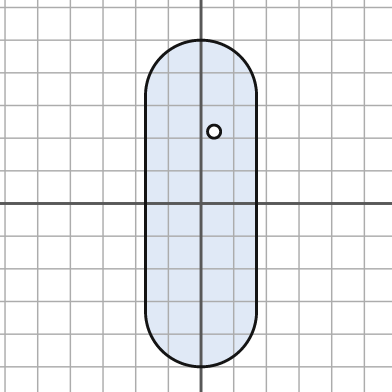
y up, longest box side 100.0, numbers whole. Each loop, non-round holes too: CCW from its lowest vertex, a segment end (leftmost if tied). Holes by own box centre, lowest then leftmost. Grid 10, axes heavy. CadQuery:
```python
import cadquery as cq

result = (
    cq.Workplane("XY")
    .moveTo(-17.0, -33.0)
    .threePointArc((0.0, -50.0), (17.0, -33.0))
    .lineTo(17.0, 33.0)
    .threePointArc((0.0, 50.0), (-17.0, 33.0))
    .close()
    .moveTo(4.0, 22.0)
    .circle(2.0)
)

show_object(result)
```